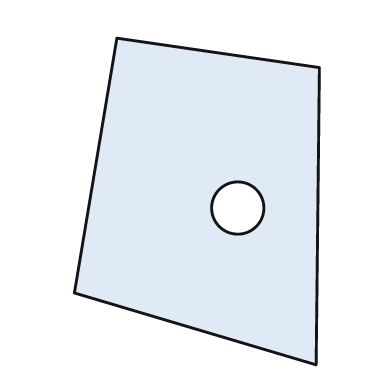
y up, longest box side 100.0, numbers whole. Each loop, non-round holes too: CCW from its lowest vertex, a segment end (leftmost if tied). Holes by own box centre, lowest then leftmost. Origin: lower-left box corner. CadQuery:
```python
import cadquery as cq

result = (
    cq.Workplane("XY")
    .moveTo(74.0, 0.0)
    .lineTo(75.0, 91.0)
    .lineTo(13.0, 100.0)
    .lineTo(0.0, 22.0)
    .close()
    .moveTo(50.0, 48.0)
    .circle(8.0)
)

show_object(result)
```